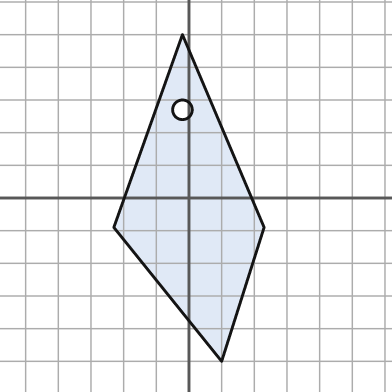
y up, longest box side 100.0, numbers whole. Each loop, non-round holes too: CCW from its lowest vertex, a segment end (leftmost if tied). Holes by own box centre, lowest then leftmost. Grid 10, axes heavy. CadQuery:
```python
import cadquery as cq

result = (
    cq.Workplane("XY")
    .moveTo(10.0, -50.0)
    .lineTo(23.0, -9.0)
    .lineTo(-2.0, 50.0)
    .lineTo(-23.0, -9.0)
    .close()
    .moveTo(-2.0, 27.0)
    .circle(3.0)
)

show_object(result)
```